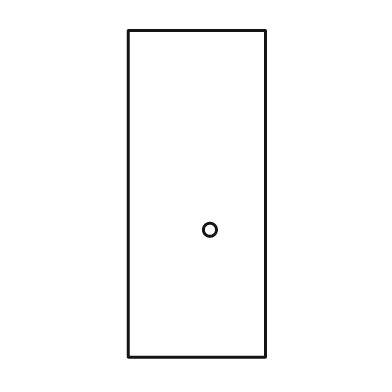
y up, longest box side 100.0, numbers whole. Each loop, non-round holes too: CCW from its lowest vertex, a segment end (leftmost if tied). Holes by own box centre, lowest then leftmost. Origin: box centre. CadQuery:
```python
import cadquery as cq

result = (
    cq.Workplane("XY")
    .moveTo(-21.0, -50.0)
    .lineTo(21.0, -50.0)
    .lineTo(21.0, 50.0)
    .lineTo(-21.0, 50.0)
    .close()
    .moveTo(4.0, -11.0)
    .circle(2.0)
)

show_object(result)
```